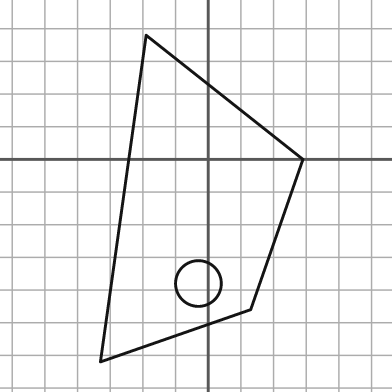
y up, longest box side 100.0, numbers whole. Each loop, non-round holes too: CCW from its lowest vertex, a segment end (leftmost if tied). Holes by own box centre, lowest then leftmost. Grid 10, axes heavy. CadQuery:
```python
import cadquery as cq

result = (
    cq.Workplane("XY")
    .moveTo(-33.0, -62.0)
    .lineTo(13.0, -46.0)
    .lineTo(29.0, 0.0)
    .lineTo(-19.0, 38.0)
    .close()
    .moveTo(-3.0, -38.0)
    .circle(7.0)
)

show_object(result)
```